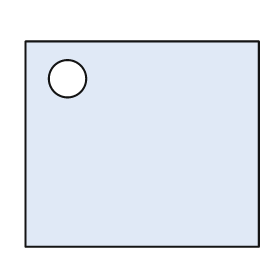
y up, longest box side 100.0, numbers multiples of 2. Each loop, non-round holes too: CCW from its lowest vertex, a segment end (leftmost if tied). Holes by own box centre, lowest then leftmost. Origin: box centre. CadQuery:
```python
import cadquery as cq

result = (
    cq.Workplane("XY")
    .moveTo(-50.0, -44.0)
    .lineTo(50.0, -44.0)
    .lineTo(50.0, 44.0)
    .lineTo(-50.0, 44.0)
    .close()
    .moveTo(-32.0, 28.0)
    .circle(8.0)
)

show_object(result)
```